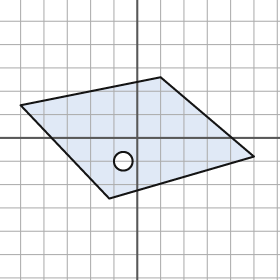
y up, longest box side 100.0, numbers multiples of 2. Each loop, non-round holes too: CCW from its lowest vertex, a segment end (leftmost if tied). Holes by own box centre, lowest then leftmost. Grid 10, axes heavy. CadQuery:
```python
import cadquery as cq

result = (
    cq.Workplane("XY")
    .moveTo(-12.0, -26.0)
    .lineTo(50.0, -8.0)
    .lineTo(10.0, 26.0)
    .lineTo(-50.0, 14.0)
    .close()
    .moveTo(-6.0, -10.0)
    .circle(4.0)
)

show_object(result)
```